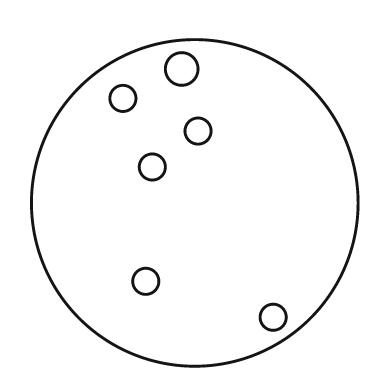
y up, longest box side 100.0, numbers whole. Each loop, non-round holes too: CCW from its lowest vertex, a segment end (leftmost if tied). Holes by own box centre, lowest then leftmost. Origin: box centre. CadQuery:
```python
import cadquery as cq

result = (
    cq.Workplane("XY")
    .moveTo(0.0, 0.0)
    .circle(50.0)
    .moveTo(24.0, -35.0)
    .circle(4.0)
    .moveTo(-15.0, -24.0)
    .circle(4.0)
    .moveTo(-13.0, 11.0)
    .circle(4.0)
    .moveTo(1.0, 22.0)
    .circle(4.0)
    .moveTo(-22.0, 32.0)
    .circle(4.0)
    .moveTo(-4.0, 41.0)
    .circle(5.0)
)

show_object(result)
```